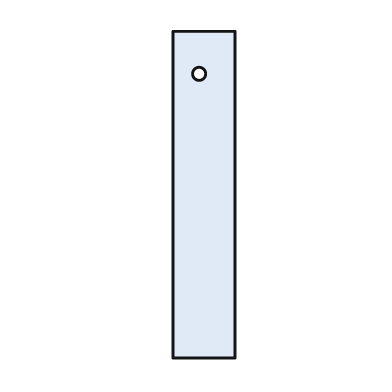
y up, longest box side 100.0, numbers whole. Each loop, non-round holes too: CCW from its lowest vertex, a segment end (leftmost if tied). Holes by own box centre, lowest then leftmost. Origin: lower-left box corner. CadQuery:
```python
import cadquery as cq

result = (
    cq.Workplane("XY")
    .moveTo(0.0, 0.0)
    .lineTo(19.0, 0.0)
    .lineTo(19.0, 100.0)
    .lineTo(0.0, 100.0)
    .close()
    .moveTo(8.0, 87.0)
    .circle(2.0)
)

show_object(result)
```